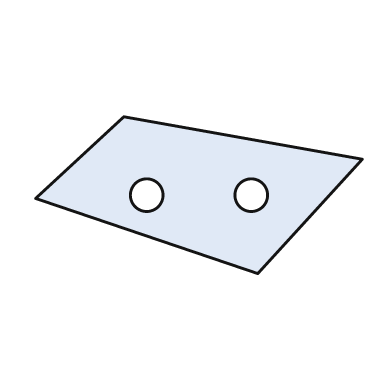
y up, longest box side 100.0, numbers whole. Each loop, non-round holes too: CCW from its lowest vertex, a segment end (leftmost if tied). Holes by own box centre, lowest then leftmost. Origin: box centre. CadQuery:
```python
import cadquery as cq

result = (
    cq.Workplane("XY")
    .moveTo(18.0, -24.0)
    .lineTo(50.0, 11.0)
    .lineTo(-23.0, 24.0)
    .lineTo(-50.0, -1.0)
    .close()
    .moveTo(-16.0, 0.0)
    .circle(5.0)
    .moveTo(16.0, 0.0)
    .circle(5.0)
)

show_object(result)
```